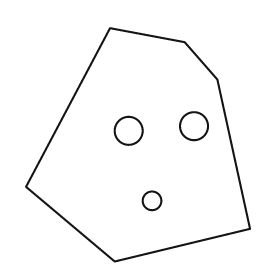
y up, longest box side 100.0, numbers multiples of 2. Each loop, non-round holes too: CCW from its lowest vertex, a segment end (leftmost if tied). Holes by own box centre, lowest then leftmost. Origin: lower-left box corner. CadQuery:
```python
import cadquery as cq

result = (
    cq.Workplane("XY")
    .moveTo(38.0, 0.0)
    .lineTo(96.0, 14.0)
    .lineTo(82.0, 78.0)
    .lineTo(68.0, 94.0)
    .lineTo(36.0, 100.0)
    .lineTo(0.0, 32.0)
    .close()
    .moveTo(54.0, 26.0)
    .circle(4.0)
    .moveTo(44.0, 56.0)
    .circle(6.0)
    .moveTo(72.0, 58.0)
    .circle(6.0)
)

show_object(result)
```